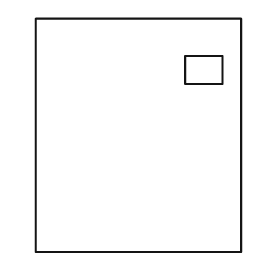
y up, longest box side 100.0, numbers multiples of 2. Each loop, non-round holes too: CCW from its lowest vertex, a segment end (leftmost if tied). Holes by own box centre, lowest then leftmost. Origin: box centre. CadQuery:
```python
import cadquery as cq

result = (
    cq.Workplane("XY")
    .moveTo(-44.0, -50.0)
    .lineTo(44.0, -50.0)
    .lineTo(44.0, 50.0)
    .lineTo(-44.0, 50.0)
    .close()
    .moveTo(20.0, 22.0)
    .lineTo(36.0, 22.0)
    .lineTo(36.0, 34.0)
    .lineTo(20.0, 34.0)
    .close()
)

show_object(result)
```